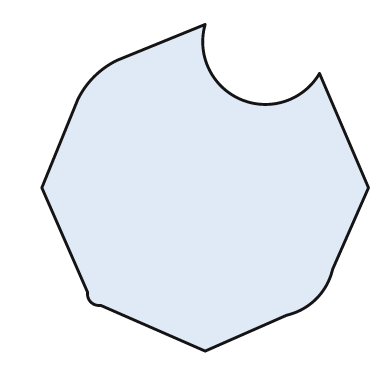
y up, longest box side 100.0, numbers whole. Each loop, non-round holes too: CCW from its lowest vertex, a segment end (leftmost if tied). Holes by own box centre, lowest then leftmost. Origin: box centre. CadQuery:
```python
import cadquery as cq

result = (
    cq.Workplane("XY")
    .moveTo(0.0, -50.0)
    .lineTo(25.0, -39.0)
    .threePointArc((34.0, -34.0), (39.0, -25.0))
    .lineTo(50.0, 0.0)
    .lineTo(35.0, 35.0)
    .threePointArc((11.0, 27.0), (0.0, 50.0))
    .lineTo(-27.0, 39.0)
    .threePointArc((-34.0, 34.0), (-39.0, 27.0))
    .lineTo(-50.0, 0.0)
    .lineTo(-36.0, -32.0)
    .threePointArc((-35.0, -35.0), (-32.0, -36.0))
    .close()
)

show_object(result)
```